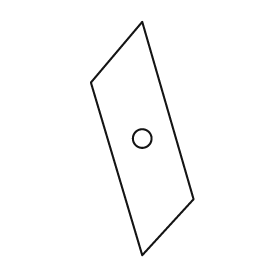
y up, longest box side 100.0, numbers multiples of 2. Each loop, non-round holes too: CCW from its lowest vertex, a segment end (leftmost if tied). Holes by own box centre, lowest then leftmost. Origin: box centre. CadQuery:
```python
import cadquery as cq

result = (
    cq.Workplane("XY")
    .moveTo(0.0, -50.0)
    .lineTo(22.0, -26.0)
    .lineTo(0.0, 50.0)
    .lineTo(-22.0, 24.0)
    .close()
    .moveTo(0.0, 0.0)
    .circle(4.0)
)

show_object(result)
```